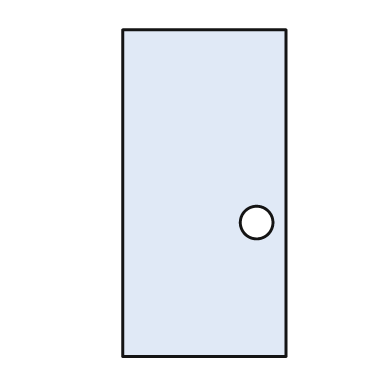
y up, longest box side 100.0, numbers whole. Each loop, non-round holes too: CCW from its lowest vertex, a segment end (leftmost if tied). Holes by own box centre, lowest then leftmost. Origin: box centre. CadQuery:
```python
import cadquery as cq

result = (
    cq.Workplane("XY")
    .moveTo(-25.0, -50.0)
    .lineTo(25.0, -50.0)
    .lineTo(25.0, 50.0)
    .lineTo(-25.0, 50.0)
    .close()
    .moveTo(16.0, -9.0)
    .circle(5.0)
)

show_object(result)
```